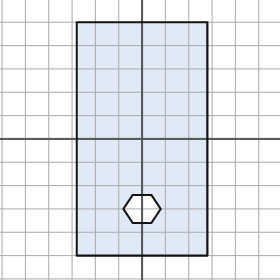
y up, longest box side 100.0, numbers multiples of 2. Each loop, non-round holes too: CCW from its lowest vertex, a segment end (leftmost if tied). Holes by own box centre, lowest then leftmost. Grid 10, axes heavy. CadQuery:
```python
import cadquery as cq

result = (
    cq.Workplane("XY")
    .moveTo(-28.0, -50.0)
    .lineTo(28.0, -50.0)
    .lineTo(28.0, 50.0)
    .lineTo(-28.0, 50.0)
    .close()
    .moveTo(-4.0, -36.0)
    .lineTo(4.0, -36.0)
    .lineTo(8.0, -30.0)
    .lineTo(4.0, -24.0)
    .lineTo(-4.0, -24.0)
    .lineTo(-8.0, -30.0)
    .close()
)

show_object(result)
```